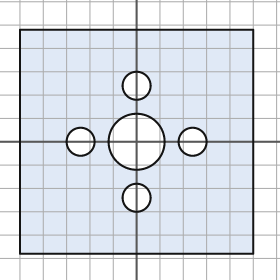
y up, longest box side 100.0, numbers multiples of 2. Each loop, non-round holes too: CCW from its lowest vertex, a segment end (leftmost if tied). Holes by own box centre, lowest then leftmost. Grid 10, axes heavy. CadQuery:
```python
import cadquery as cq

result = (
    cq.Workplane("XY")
    .moveTo(-50.0, -48.0)
    .lineTo(50.0, -48.0)
    .lineTo(50.0, 48.0)
    .lineTo(-50.0, 48.0)
    .close()
    .moveTo(0.0, -24.0)
    .circle(6.0)
    .moveTo(-24.0, 0.0)
    .circle(6.0)
    .moveTo(0.0, 0.0)
    .circle(12.0)
    .moveTo(24.0, 0.0)
    .circle(6.0)
    .moveTo(0.0, 24.0)
    .circle(6.0)
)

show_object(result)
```